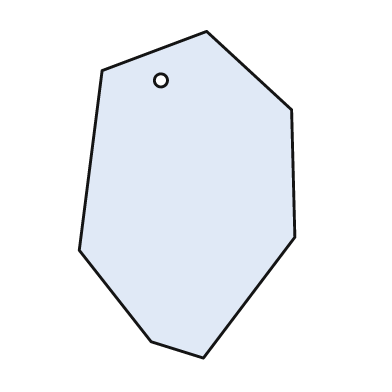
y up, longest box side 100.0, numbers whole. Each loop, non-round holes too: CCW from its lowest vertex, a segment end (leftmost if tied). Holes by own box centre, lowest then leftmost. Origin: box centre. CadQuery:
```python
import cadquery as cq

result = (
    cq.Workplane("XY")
    .moveTo(5.0, -50.0)
    .lineTo(33.0, -13.0)
    .lineTo(32.0, 26.0)
    .lineTo(6.0, 50.0)
    .lineTo(-26.0, 38.0)
    .lineTo(-33.0, -17.0)
    .lineTo(-11.0, -45.0)
    .close()
    .moveTo(-8.0, 35.0)
    .circle(2.0)
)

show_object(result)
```